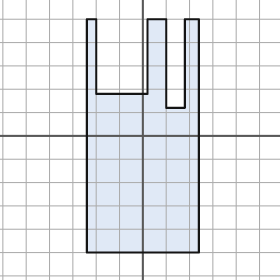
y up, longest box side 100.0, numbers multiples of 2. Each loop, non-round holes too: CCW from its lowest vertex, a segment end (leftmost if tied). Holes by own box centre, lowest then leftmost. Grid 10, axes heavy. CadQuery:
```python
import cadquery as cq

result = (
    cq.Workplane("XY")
    .moveTo(-24.0, -50.0)
    .lineTo(24.0, -50.0)
    .lineTo(24.0, 50.0)
    .lineTo(18.0, 50.0)
    .lineTo(18.0, 12.0)
    .lineTo(10.0, 12.0)
    .lineTo(10.0, 50.0)
    .lineTo(2.0, 50.0)
    .lineTo(2.0, 18.0)
    .lineTo(-20.0, 18.0)
    .lineTo(-20.0, 50.0)
    .lineTo(-24.0, 50.0)
    .close()
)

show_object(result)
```